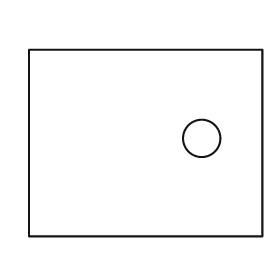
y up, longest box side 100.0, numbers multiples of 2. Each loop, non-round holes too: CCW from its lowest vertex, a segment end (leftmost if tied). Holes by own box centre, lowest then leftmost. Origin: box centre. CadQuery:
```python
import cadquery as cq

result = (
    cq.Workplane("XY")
    .moveTo(-50.0, -40.0)
    .lineTo(50.0, -40.0)
    .lineTo(50.0, 40.0)
    .lineTo(-50.0, 40.0)
    .close()
    .moveTo(24.0, 2.0)
    .circle(8.0)
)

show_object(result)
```